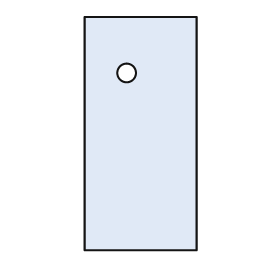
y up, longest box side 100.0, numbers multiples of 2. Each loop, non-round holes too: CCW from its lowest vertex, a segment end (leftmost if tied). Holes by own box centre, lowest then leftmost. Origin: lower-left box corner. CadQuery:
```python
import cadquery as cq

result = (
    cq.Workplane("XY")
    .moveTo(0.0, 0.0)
    .lineTo(48.0, 0.0)
    .lineTo(48.0, 100.0)
    .lineTo(0.0, 100.0)
    .close()
    .moveTo(18.0, 76.0)
    .circle(4.0)
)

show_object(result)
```